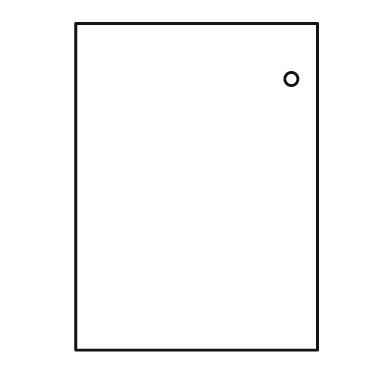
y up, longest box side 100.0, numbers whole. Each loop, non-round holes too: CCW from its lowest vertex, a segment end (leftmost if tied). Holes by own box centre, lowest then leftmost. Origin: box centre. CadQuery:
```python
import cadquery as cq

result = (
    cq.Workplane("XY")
    .moveTo(-37.0, -50.0)
    .lineTo(37.0, -50.0)
    .lineTo(37.0, 50.0)
    .lineTo(-37.0, 50.0)
    .close()
    .moveTo(29.0, 33.0)
    .circle(2.0)
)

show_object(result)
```